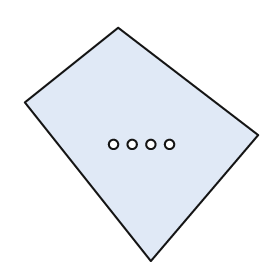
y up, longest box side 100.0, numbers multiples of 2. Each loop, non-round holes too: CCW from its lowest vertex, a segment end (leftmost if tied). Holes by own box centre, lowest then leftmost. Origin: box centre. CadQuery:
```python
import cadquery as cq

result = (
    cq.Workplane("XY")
    .moveTo(4.0, -50.0)
    .lineTo(50.0, 4.0)
    .lineTo(-10.0, 50.0)
    .lineTo(-50.0, 18.0)
    .close()
    .moveTo(-12.0, 0.0)
    .circle(2.0)
    .moveTo(-4.0, 0.0)
    .circle(2.0)
    .moveTo(4.0, 0.0)
    .circle(2.0)
    .moveTo(12.0, 0.0)
    .circle(2.0)
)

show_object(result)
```